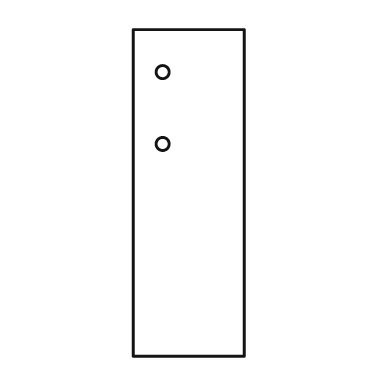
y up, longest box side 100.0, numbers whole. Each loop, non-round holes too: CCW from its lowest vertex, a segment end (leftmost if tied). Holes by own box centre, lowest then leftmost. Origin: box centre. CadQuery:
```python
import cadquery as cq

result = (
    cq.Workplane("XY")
    .moveTo(-17.0, -50.0)
    .lineTo(17.0, -50.0)
    .lineTo(17.0, 50.0)
    .lineTo(-17.0, 50.0)
    .close()
    .moveTo(-8.0, 15.0)
    .circle(2.0)
    .moveTo(-8.0, 37.0)
    .circle(2.0)
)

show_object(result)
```